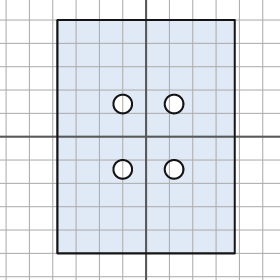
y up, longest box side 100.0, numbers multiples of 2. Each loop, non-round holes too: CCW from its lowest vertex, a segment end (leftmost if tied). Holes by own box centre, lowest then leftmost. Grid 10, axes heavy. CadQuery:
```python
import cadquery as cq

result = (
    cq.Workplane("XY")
    .moveTo(-38.0, -50.0)
    .lineTo(38.0, -50.0)
    .lineTo(38.0, 50.0)
    .lineTo(-38.0, 50.0)
    .close()
    .moveTo(-10.0, -14.0)
    .circle(4.0)
    .moveTo(12.0, -14.0)
    .circle(4.0)
    .moveTo(-10.0, 14.0)
    .circle(4.0)
    .moveTo(12.0, 14.0)
    .circle(4.0)
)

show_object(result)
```